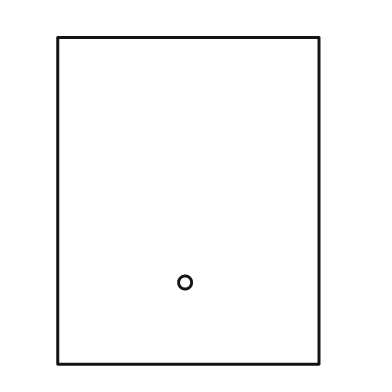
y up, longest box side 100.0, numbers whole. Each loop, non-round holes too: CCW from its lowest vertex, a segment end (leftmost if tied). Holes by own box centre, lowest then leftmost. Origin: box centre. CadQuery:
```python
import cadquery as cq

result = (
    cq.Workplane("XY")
    .moveTo(-40.0, -50.0)
    .lineTo(40.0, -50.0)
    .lineTo(40.0, 50.0)
    .lineTo(-40.0, 50.0)
    .close()
    .moveTo(-1.0, -25.0)
    .circle(2.0)
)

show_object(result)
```